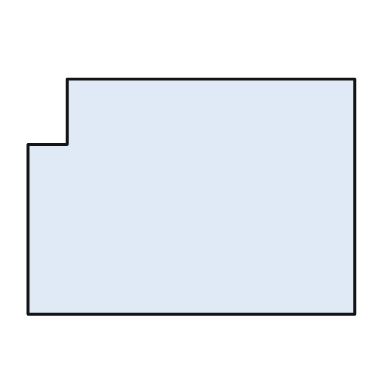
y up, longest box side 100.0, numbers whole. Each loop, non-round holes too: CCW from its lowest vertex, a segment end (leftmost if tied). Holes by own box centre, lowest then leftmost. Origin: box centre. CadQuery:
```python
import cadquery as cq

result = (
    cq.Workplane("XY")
    .moveTo(-50.0, -36.0)
    .lineTo(50.0, -36.0)
    .lineTo(50.0, 36.0)
    .lineTo(-38.0, 36.0)
    .lineTo(-38.0, 16.0)
    .lineTo(-50.0, 16.0)
    .close()
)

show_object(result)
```